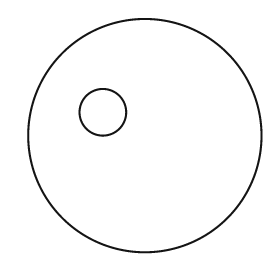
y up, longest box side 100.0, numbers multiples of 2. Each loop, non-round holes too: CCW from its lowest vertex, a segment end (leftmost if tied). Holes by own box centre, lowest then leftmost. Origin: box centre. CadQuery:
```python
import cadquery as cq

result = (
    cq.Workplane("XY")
    .moveTo(0.0, 0.0)
    .circle(50.0)
    .moveTo(-18.0, 10.0)
    .circle(10.0)
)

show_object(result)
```